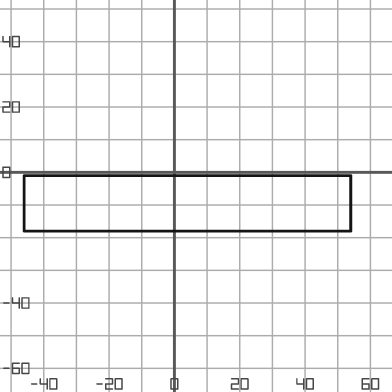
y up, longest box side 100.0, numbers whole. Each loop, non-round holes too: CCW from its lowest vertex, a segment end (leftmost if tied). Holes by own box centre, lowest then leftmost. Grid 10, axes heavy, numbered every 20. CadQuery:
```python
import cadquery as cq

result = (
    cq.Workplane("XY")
    .moveTo(-46.0, -18.0)
    .lineTo(54.0, -18.0)
    .lineTo(54.0, -1.0)
    .lineTo(-46.0, -1.0)
    .close()
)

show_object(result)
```